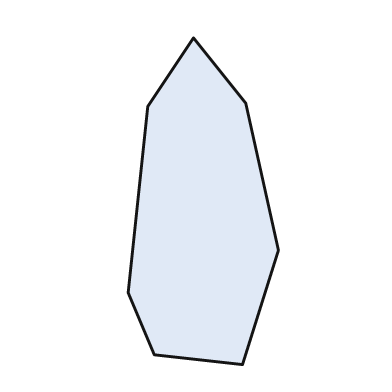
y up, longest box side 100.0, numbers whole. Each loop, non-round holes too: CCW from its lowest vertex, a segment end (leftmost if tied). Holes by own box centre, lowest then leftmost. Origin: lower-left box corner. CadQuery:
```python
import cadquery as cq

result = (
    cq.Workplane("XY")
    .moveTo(35.0, 0.0)
    .lineTo(46.0, 35.0)
    .lineTo(36.0, 80.0)
    .lineTo(20.0, 100.0)
    .lineTo(6.0, 79.0)
    .lineTo(0.0, 22.0)
    .lineTo(8.0, 3.0)
    .close()
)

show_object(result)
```